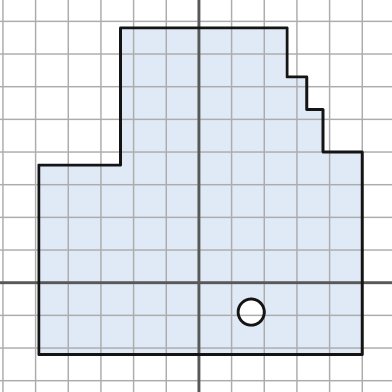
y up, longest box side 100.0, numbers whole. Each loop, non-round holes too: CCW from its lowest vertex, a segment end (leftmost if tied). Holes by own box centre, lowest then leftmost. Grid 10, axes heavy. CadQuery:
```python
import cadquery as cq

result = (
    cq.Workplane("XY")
    .moveTo(-49.0, -22.0)
    .lineTo(50.0, -22.0)
    .lineTo(50.0, 40.0)
    .lineTo(38.0, 40.0)
    .lineTo(38.0, 53.0)
    .lineTo(33.0, 53.0)
    .lineTo(33.0, 63.0)
    .lineTo(27.0, 63.0)
    .lineTo(27.0, 78.0)
    .lineTo(-24.0, 78.0)
    .lineTo(-24.0, 36.0)
    .lineTo(-49.0, 36.0)
    .close()
    .moveTo(16.0, -9.0)
    .circle(4.0)
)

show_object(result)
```